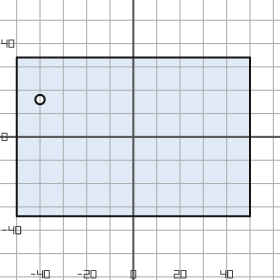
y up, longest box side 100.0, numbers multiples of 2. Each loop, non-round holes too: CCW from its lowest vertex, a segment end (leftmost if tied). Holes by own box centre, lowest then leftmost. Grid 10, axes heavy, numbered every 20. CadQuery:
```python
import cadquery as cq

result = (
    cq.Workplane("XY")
    .moveTo(-50.0, -34.0)
    .lineTo(50.0, -34.0)
    .lineTo(50.0, 34.0)
    .lineTo(-50.0, 34.0)
    .close()
    .moveTo(-40.0, 16.0)
    .circle(2.0)
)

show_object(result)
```